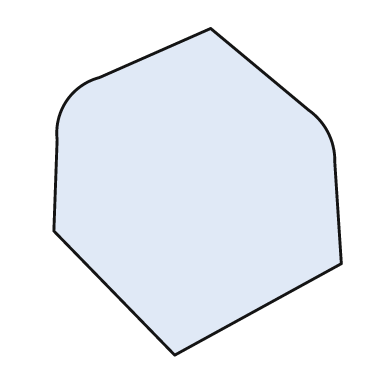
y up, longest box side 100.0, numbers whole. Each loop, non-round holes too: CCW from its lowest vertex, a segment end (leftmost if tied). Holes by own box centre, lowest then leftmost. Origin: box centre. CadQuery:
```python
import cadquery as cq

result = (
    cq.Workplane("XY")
    .moveTo(-7.0, -50.0)
    .lineTo(44.0, -22.0)
    .lineTo(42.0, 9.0)
    .threePointArc((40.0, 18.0), (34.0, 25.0))
    .lineTo(4.0, 50.0)
    .lineTo(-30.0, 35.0)
    .threePointArc((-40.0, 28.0), (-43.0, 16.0))
    .lineTo(-44.0, -12.0)
    .close()
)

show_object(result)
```